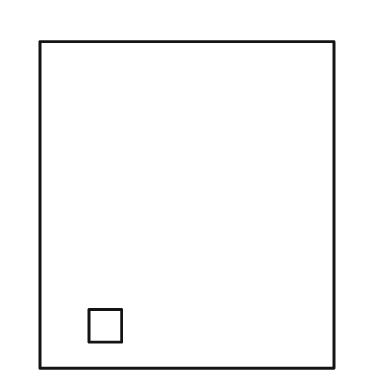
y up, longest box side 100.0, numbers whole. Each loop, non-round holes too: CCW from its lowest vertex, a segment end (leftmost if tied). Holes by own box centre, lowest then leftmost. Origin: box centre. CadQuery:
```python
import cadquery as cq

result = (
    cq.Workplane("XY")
    .moveTo(-45.0, -50.0)
    .lineTo(45.0, -50.0)
    .lineTo(45.0, 50.0)
    .lineTo(-45.0, 50.0)
    .close()
    .moveTo(-30.0, -42.0)
    .lineTo(-20.0, -42.0)
    .lineTo(-20.0, -32.0)
    .lineTo(-30.0, -32.0)
    .close()
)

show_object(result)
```